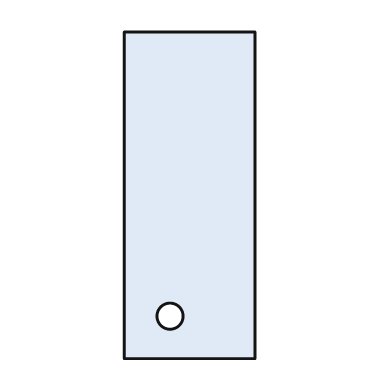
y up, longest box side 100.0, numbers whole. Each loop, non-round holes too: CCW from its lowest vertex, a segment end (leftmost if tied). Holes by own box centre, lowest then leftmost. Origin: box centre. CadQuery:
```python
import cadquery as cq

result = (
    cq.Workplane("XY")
    .moveTo(-20.0, -50.0)
    .lineTo(20.0, -50.0)
    .lineTo(20.0, 50.0)
    .lineTo(-20.0, 50.0)
    .close()
    .moveTo(-6.0, -37.0)
    .circle(4.0)
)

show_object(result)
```